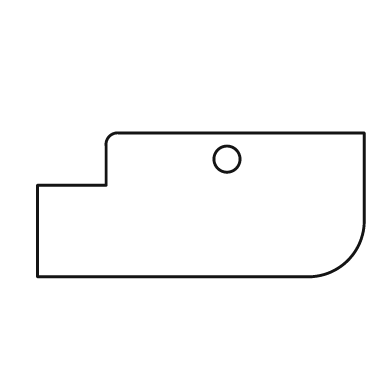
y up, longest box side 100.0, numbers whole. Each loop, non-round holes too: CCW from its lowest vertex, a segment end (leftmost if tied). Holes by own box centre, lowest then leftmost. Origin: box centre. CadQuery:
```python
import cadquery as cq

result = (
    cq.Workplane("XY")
    .moveTo(-50.0, -22.0)
    .lineTo(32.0, -22.0)
    .threePointArc((45.0, -17.0), (50.0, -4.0))
    .lineTo(50.0, 22.0)
    .lineTo(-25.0, 22.0)
    .threePointArc((-28.0, 21.0), (-29.0, 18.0))
    .lineTo(-29.0, 6.0)
    .lineTo(-50.0, 6.0)
    .close()
    .moveTo(8.0, 14.0)
    .circle(4.0)
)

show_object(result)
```